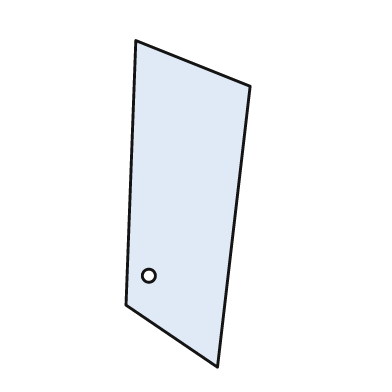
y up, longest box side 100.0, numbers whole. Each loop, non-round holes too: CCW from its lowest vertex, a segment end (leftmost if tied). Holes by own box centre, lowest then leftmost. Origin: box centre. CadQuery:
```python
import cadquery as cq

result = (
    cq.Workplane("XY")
    .moveTo(9.0, -50.0)
    .lineTo(19.0, 36.0)
    .lineTo(-16.0, 50.0)
    .lineTo(-19.0, -31.0)
    .close()
    .moveTo(-12.0, -22.0)
    .circle(2.0)
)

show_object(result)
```